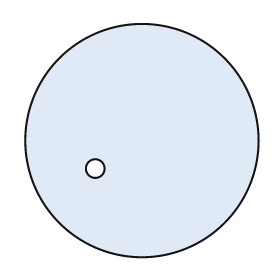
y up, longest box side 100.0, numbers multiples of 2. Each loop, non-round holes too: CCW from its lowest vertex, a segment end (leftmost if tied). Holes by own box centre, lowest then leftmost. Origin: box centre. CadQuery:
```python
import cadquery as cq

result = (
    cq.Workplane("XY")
    .moveTo(0.0, 0.0)
    .circle(50.0)
    .moveTo(-20.0, -12.0)
    .circle(4.0)
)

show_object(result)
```